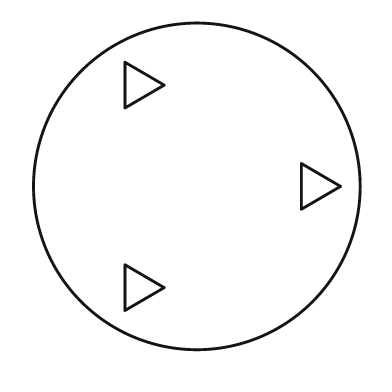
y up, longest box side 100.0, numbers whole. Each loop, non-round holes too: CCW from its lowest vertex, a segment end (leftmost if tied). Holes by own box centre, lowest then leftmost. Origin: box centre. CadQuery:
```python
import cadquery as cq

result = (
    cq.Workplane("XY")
    .moveTo(0.0, 0.0)
    .circle(50.0)
    .moveTo(-22.0, -38.0)
    .lineTo(-10.0, -31.0)
    .lineTo(-22.0, -24.0)
    .close()
    .moveTo(32.0, -7.0)
    .lineTo(44.0, 0.0)
    .lineTo(32.0, 7.0)
    .close()
    .moveTo(-22.0, 24.0)
    .lineTo(-10.0, 31.0)
    .lineTo(-22.0, 38.0)
    .close()
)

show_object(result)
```